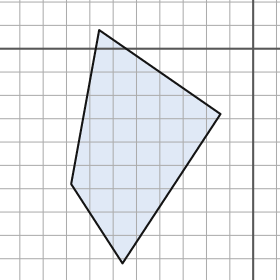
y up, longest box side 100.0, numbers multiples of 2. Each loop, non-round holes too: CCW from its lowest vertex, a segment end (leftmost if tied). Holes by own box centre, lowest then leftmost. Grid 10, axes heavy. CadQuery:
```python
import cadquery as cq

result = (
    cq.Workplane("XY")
    .moveTo(-56.0, -92.0)
    .lineTo(-14.0, -28.0)
    .lineTo(-66.0, 8.0)
    .lineTo(-78.0, -58.0)
    .close()
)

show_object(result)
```